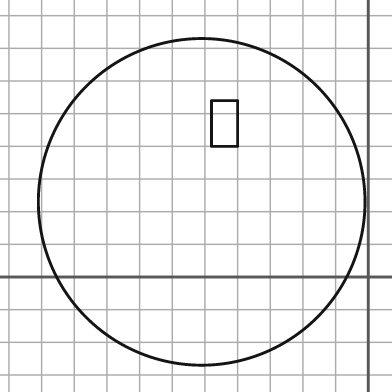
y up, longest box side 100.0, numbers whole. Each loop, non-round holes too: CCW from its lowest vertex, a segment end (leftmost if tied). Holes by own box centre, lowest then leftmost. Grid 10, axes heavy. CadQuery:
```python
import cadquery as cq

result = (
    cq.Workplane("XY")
    .moveTo(-51.0, 23.0)
    .circle(50.0)
    .moveTo(-48.0, 40.0)
    .lineTo(-40.0, 40.0)
    .lineTo(-40.0, 54.0)
    .lineTo(-48.0, 54.0)
    .close()
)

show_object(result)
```